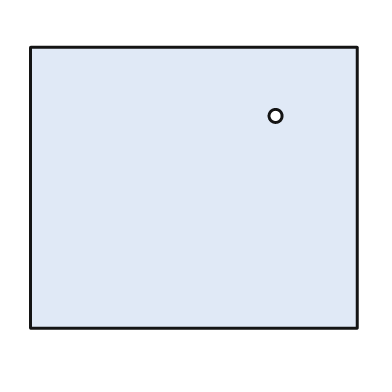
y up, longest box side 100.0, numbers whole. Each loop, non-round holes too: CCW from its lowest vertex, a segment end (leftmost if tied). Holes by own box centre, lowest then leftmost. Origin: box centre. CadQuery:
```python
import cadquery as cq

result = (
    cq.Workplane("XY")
    .moveTo(-50.0, -43.0)
    .lineTo(50.0, -43.0)
    .lineTo(50.0, 43.0)
    .lineTo(-50.0, 43.0)
    .close()
    .moveTo(25.0, 22.0)
    .circle(2.0)
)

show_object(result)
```